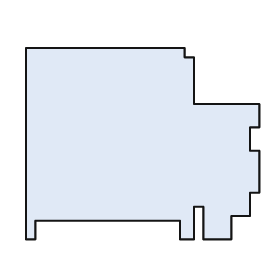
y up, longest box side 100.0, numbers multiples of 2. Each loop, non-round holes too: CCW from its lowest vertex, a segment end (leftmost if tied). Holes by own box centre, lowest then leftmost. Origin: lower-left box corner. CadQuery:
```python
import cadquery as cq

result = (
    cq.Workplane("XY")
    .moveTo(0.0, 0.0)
    .lineTo(4.0, 0.0)
    .lineTo(4.0, 8.0)
    .lineTo(66.0, 8.0)
    .lineTo(66.0, 0.0)
    .lineTo(72.0, 0.0)
    .lineTo(72.0, 14.0)
    .lineTo(76.0, 14.0)
    .lineTo(76.0, 0.0)
    .lineTo(88.0, 0.0)
    .lineTo(88.0, 10.0)
    .lineTo(96.0, 10.0)
    .lineTo(96.0, 20.0)
    .lineTo(100.0, 20.0)
    .lineTo(100.0, 38.0)
    .lineTo(96.0, 38.0)
    .lineTo(96.0, 48.0)
    .lineTo(100.0, 48.0)
    .lineTo(100.0, 58.0)
    .lineTo(72.0, 58.0)
    .lineTo(72.0, 78.0)
    .lineTo(68.0, 78.0)
    .lineTo(68.0, 82.0)
    .lineTo(0.0, 82.0)
    .close()
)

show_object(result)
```